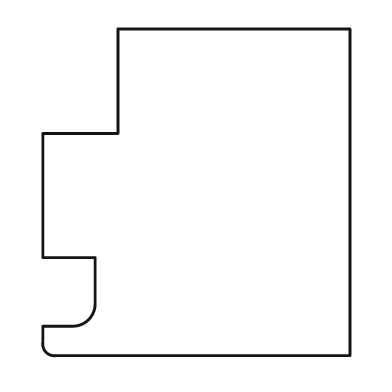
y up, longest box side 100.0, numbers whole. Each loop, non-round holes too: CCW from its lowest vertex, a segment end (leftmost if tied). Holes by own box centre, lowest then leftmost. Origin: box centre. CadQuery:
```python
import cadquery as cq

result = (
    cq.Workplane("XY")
    .moveTo(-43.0, -50.0)
    .lineTo(47.0, -50.0)
    .lineTo(47.0, 50.0)
    .lineTo(-24.0, 50.0)
    .lineTo(-24.0, 18.0)
    .lineTo(-47.0, 18.0)
    .lineTo(-47.0, -20.0)
    .lineTo(-31.0, -20.0)
    .lineTo(-31.0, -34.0)
    .threePointArc((-33.0, -39.0), (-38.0, -41.0))
    .lineTo(-47.0, -41.0)
    .lineTo(-47.0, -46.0)
    .threePointArc((-46.0, -49.0), (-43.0, -50.0))
    .close()
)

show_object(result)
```